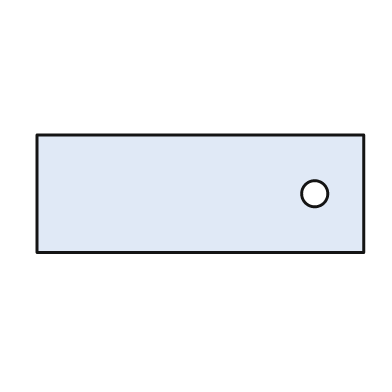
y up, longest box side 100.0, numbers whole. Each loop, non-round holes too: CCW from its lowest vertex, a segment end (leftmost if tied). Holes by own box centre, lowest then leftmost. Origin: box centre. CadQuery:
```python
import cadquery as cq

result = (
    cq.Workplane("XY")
    .moveTo(-50.0, -18.0)
    .lineTo(50.0, -18.0)
    .lineTo(50.0, 18.0)
    .lineTo(-50.0, 18.0)
    .close()
    .moveTo(35.0, 0.0)
    .circle(4.0)
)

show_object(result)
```